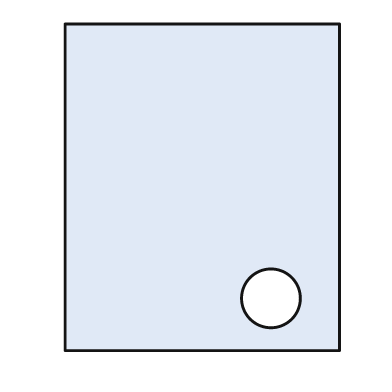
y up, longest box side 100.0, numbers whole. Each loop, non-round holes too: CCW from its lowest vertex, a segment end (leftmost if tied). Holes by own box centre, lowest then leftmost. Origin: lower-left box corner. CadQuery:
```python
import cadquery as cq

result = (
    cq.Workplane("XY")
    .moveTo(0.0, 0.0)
    .lineTo(84.0, 0.0)
    .lineTo(84.0, 100.0)
    .lineTo(0.0, 100.0)
    .close()
    .moveTo(63.0, 16.0)
    .circle(9.0)
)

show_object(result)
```